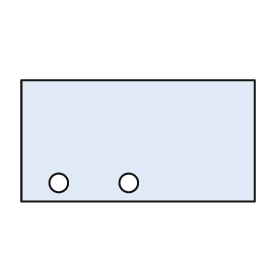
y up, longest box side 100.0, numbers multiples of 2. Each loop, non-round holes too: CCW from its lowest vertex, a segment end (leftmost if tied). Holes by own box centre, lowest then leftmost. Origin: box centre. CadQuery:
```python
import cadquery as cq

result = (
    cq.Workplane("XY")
    .moveTo(-50.0, -26.0)
    .lineTo(50.0, -26.0)
    .lineTo(50.0, 26.0)
    .lineTo(-50.0, 26.0)
    .close()
    .moveTo(-34.0, -18.0)
    .circle(4.0)
    .moveTo(-4.0, -18.0)
    .circle(4.0)
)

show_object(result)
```